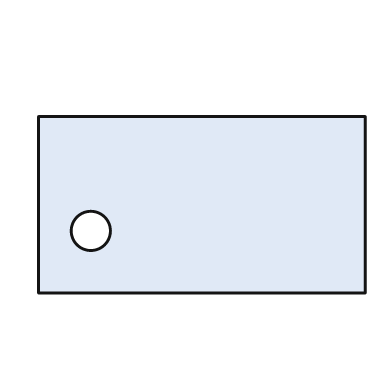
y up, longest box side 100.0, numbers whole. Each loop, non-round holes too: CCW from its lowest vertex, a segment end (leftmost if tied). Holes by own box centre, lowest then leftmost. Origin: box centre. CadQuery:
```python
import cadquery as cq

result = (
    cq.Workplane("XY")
    .moveTo(-50.0, -27.0)
    .lineTo(50.0, -27.0)
    .lineTo(50.0, 27.0)
    .lineTo(-50.0, 27.0)
    .close()
    .moveTo(-34.0, -8.0)
    .circle(6.0)
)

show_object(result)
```